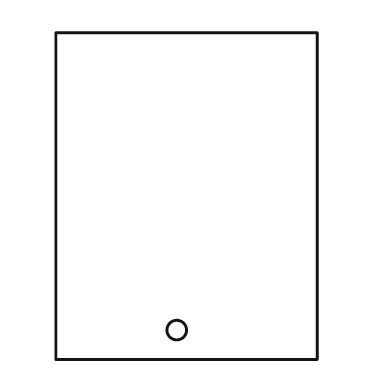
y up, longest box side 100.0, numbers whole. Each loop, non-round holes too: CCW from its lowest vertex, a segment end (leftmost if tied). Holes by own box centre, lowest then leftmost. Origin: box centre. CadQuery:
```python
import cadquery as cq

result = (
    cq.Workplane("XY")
    .moveTo(-40.0, -50.0)
    .lineTo(40.0, -50.0)
    .lineTo(40.0, 50.0)
    .lineTo(-40.0, 50.0)
    .close()
    .moveTo(-3.0, -41.0)
    .circle(3.0)
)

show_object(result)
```